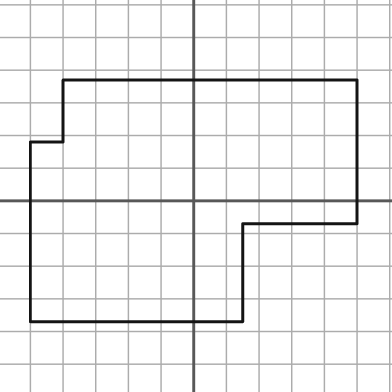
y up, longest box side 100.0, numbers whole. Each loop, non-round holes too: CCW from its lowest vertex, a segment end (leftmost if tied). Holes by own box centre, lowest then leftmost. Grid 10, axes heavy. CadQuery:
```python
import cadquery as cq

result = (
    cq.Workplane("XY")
    .moveTo(-50.0, -37.0)
    .lineTo(15.0, -37.0)
    .lineTo(15.0, -7.0)
    .lineTo(50.0, -7.0)
    .lineTo(50.0, 37.0)
    .lineTo(-40.0, 37.0)
    .lineTo(-40.0, 18.0)
    .lineTo(-50.0, 18.0)
    .close()
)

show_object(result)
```